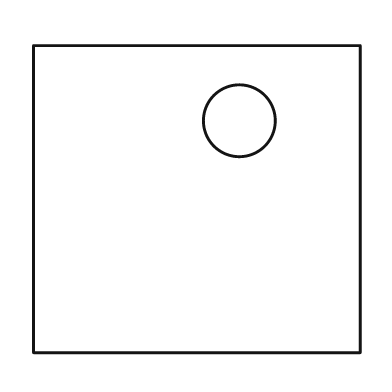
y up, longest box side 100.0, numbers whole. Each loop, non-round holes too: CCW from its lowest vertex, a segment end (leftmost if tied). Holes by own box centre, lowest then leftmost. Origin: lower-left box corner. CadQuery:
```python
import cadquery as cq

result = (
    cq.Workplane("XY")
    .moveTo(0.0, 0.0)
    .lineTo(100.0, 0.0)
    .lineTo(100.0, 94.0)
    .lineTo(0.0, 94.0)
    .close()
    .moveTo(63.0, 71.0)
    .circle(11.0)
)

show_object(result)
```